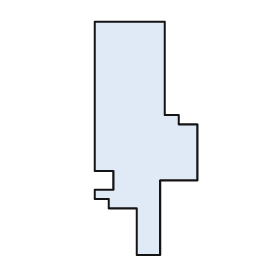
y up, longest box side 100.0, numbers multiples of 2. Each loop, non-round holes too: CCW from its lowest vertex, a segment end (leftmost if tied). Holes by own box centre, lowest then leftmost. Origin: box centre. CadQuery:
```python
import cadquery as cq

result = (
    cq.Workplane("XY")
    .moveTo(-4.0, -50.0)
    .lineTo(6.0, -50.0)
    .lineTo(6.0, -18.0)
    .lineTo(22.0, -18.0)
    .lineTo(22.0, 6.0)
    .lineTo(14.0, 6.0)
    .lineTo(14.0, 10.0)
    .lineTo(8.0, 10.0)
    .lineTo(8.0, 50.0)
    .lineTo(-22.0, 50.0)
    .lineTo(-22.0, -14.0)
    .lineTo(-14.0, -14.0)
    .lineTo(-14.0, -22.0)
    .lineTo(-22.0, -22.0)
    .lineTo(-22.0, -26.0)
    .lineTo(-16.0, -26.0)
    .lineTo(-16.0, -30.0)
    .lineTo(-4.0, -30.0)
    .close()
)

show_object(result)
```